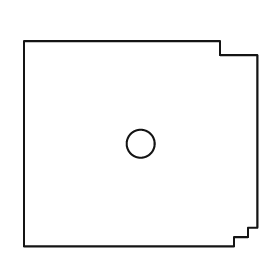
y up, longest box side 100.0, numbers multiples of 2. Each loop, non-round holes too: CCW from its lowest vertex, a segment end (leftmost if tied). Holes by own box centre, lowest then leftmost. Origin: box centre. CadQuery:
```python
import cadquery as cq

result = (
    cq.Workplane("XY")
    .moveTo(-50.0, -44.0)
    .lineTo(40.0, -44.0)
    .lineTo(40.0, -40.0)
    .lineTo(46.0, -40.0)
    .lineTo(46.0, -36.0)
    .lineTo(50.0, -36.0)
    .lineTo(50.0, 38.0)
    .lineTo(34.0, 38.0)
    .lineTo(34.0, 44.0)
    .lineTo(-50.0, 44.0)
    .close()
    .moveTo(0.0, 0.0)
    .circle(6.0)
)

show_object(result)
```